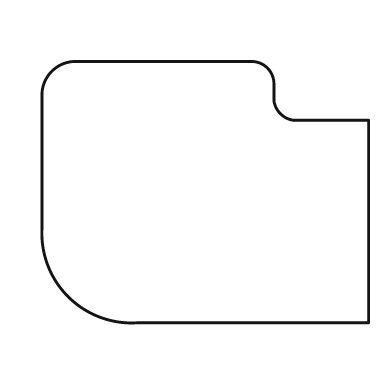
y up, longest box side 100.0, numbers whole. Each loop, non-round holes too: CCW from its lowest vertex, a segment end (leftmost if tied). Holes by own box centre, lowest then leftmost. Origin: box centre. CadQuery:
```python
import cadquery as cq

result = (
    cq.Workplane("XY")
    .moveTo(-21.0, -40.0)
    .lineTo(50.0, -40.0)
    .lineTo(50.0, 22.0)
    .lineTo(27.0, 22.0)
    .threePointArc((23.0, 24.0), (21.0, 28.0))
    .lineTo(21.0, 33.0)
    .threePointArc((19.0, 38.0), (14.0, 40.0))
    .lineTo(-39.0, 40.0)
    .threePointArc((-47.0, 37.0), (-50.0, 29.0))
    .lineTo(-50.0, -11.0)
    .threePointArc((-42.0, -32.0), (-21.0, -40.0))
    .close()
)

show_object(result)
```